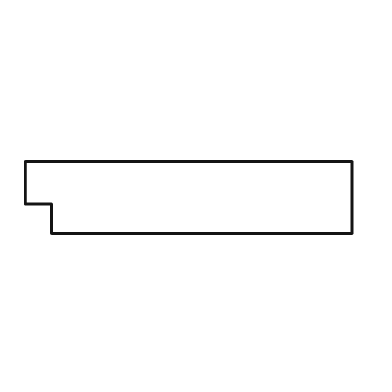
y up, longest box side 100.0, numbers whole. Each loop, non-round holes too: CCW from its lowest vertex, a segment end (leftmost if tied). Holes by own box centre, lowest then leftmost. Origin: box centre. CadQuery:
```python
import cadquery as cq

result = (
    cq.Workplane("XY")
    .moveTo(-42.0, -11.0)
    .lineTo(50.0, -11.0)
    .lineTo(50.0, 11.0)
    .lineTo(-50.0, 11.0)
    .lineTo(-50.0, -2.0)
    .lineTo(-42.0, -2.0)
    .close()
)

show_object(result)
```